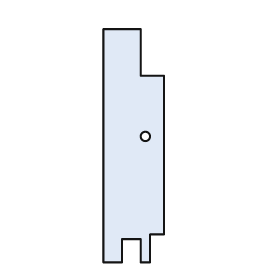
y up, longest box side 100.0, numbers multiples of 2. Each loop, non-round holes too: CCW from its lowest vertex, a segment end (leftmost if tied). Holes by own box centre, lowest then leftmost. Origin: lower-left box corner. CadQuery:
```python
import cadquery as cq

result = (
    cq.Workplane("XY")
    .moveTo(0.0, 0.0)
    .lineTo(8.0, 0.0)
    .lineTo(8.0, 10.0)
    .lineTo(16.0, 10.0)
    .lineTo(16.0, 0.0)
    .lineTo(20.0, 0.0)
    .lineTo(20.0, 12.0)
    .lineTo(26.0, 12.0)
    .lineTo(26.0, 80.0)
    .lineTo(16.0, 80.0)
    .lineTo(16.0, 100.0)
    .lineTo(0.0, 100.0)
    .close()
    .moveTo(18.0, 54.0)
    .circle(2.0)
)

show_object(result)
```